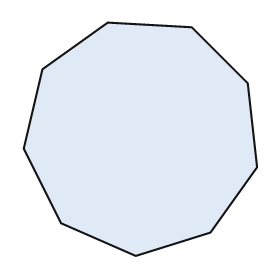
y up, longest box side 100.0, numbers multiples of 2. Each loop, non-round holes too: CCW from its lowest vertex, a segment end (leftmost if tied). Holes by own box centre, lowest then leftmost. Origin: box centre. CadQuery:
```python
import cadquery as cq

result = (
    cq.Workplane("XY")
    .moveTo(-2.0, -50.0)
    .lineTo(30.0, -40.0)
    .lineTo(50.0, -12.0)
    .lineTo(46.0, 24.0)
    .lineTo(22.0, 48.0)
    .lineTo(-14.0, 50.0)
    .lineTo(-42.0, 30.0)
    .lineTo(-50.0, -4.0)
    .lineTo(-34.0, -36.0)
    .close()
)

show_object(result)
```